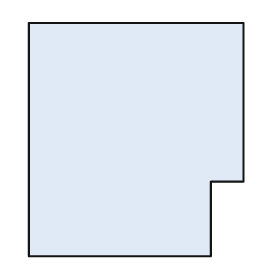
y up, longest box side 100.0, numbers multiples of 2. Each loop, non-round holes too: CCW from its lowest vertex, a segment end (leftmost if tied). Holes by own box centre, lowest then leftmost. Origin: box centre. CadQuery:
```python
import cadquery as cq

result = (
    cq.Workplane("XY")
    .moveTo(-46.0, -50.0)
    .lineTo(32.0, -50.0)
    .lineTo(32.0, -18.0)
    .lineTo(46.0, -18.0)
    .lineTo(46.0, 50.0)
    .lineTo(-46.0, 50.0)
    .close()
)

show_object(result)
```